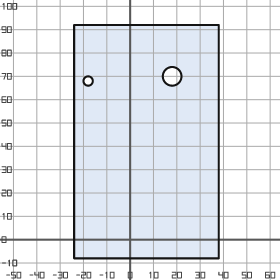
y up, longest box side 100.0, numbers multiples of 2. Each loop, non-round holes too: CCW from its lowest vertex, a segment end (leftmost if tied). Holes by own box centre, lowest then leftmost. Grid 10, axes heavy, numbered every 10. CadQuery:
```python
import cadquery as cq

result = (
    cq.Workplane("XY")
    .moveTo(-24.0, -8.0)
    .lineTo(38.0, -8.0)
    .lineTo(38.0, 92.0)
    .lineTo(-24.0, 92.0)
    .close()
    .moveTo(-18.0, 68.0)
    .circle(2.0)
    .moveTo(18.0, 70.0)
    .circle(4.0)
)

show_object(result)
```